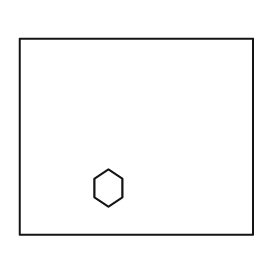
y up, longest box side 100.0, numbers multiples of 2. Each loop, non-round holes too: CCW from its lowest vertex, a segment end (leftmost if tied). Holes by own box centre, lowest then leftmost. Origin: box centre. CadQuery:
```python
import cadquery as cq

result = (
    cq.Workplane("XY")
    .moveTo(-50.0, -42.0)
    .lineTo(50.0, -42.0)
    .lineTo(50.0, 42.0)
    .lineTo(-50.0, 42.0)
    .close()
    .moveTo(-12.0, -30.0)
    .lineTo(-6.0, -26.0)
    .lineTo(-6.0, -18.0)
    .lineTo(-12.0, -14.0)
    .lineTo(-18.0, -18.0)
    .lineTo(-18.0, -26.0)
    .close()
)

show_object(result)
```